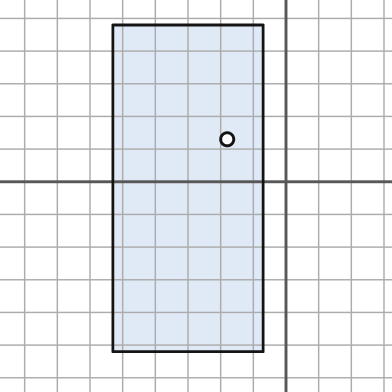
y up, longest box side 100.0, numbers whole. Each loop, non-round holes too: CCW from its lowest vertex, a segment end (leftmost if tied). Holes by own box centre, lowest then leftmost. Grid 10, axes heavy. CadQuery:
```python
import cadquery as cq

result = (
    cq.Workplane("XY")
    .moveTo(-53.0, -52.0)
    .lineTo(-7.0, -52.0)
    .lineTo(-7.0, 48.0)
    .lineTo(-53.0, 48.0)
    .close()
    .moveTo(-18.0, 13.0)
    .circle(2.0)
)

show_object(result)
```